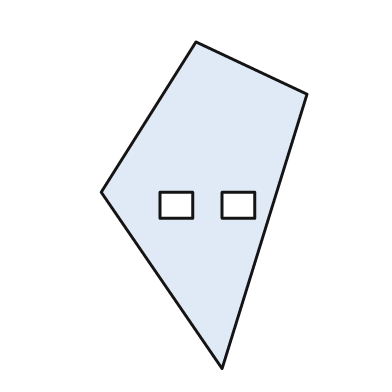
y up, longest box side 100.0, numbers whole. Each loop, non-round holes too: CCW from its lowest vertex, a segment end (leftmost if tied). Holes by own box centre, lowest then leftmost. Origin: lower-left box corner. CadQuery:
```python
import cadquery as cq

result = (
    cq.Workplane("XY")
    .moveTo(37.0, 0.0)
    .lineTo(63.0, 84.0)
    .lineTo(29.0, 100.0)
    .lineTo(0.0, 54.0)
    .close()
    .moveTo(18.0, 46.0)
    .lineTo(28.0, 46.0)
    .lineTo(28.0, 54.0)
    .lineTo(18.0, 54.0)
    .close()
    .moveTo(37.0, 46.0)
    .lineTo(47.0, 46.0)
    .lineTo(47.0, 54.0)
    .lineTo(37.0, 54.0)
    .close()
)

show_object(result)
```